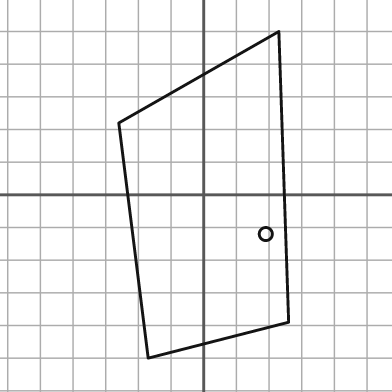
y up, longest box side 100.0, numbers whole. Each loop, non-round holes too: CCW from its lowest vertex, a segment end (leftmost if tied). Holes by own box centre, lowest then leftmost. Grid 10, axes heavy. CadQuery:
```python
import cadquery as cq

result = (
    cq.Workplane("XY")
    .moveTo(-17.0, -50.0)
    .lineTo(26.0, -39.0)
    .lineTo(23.0, 50.0)
    .lineTo(-26.0, 22.0)
    .close()
    .moveTo(19.0, -12.0)
    .circle(2.0)
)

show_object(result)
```